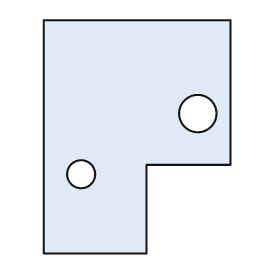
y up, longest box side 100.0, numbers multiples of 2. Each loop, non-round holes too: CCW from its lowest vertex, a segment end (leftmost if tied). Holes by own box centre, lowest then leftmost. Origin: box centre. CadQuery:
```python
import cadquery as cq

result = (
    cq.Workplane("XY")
    .moveTo(-40.0, -50.0)
    .lineTo(4.0, -50.0)
    .lineTo(4.0, -12.0)
    .lineTo(40.0, -12.0)
    .lineTo(40.0, 50.0)
    .lineTo(-40.0, 50.0)
    .close()
    .moveTo(-24.0, -16.0)
    .circle(6.0)
    .moveTo(26.0, 10.0)
    .circle(8.0)
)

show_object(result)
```